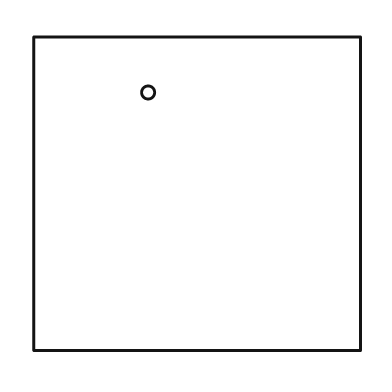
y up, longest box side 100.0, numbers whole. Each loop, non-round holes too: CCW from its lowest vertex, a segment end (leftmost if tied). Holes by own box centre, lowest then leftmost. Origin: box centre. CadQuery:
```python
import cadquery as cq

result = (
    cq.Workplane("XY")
    .moveTo(-50.0, -48.0)
    .lineTo(50.0, -48.0)
    .lineTo(50.0, 48.0)
    .lineTo(-50.0, 48.0)
    .close()
    .moveTo(-15.0, 31.0)
    .circle(2.0)
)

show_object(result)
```